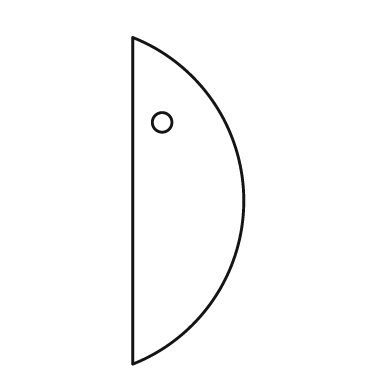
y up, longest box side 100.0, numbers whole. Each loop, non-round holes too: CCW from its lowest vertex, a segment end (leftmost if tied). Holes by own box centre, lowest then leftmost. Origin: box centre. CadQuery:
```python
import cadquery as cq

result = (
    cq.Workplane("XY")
    .moveTo(-17.0, -50.0)
    .threePointArc((17.0, 0.0), (-17.0, 50.0))
    .close()
    .moveTo(-8.0, 24.0)
    .circle(3.0)
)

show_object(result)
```